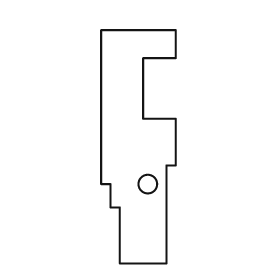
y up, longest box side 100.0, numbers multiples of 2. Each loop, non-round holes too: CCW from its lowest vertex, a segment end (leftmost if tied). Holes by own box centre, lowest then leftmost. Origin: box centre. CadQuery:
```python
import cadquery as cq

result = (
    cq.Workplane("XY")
    .moveTo(-8.0, -50.0)
    .lineTo(12.0, -50.0)
    .lineTo(12.0, -8.0)
    .lineTo(16.0, -8.0)
    .lineTo(16.0, 12.0)
    .lineTo(2.0, 12.0)
    .lineTo(2.0, 38.0)
    .lineTo(16.0, 38.0)
    .lineTo(16.0, 50.0)
    .lineTo(-16.0, 50.0)
    .lineTo(-16.0, -16.0)
    .lineTo(-12.0, -16.0)
    .lineTo(-12.0, -26.0)
    .lineTo(-8.0, -26.0)
    .close()
    .moveTo(4.0, -16.0)
    .circle(4.0)
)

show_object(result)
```